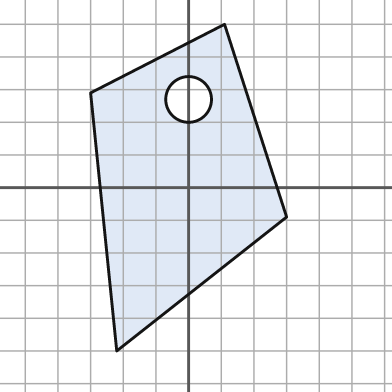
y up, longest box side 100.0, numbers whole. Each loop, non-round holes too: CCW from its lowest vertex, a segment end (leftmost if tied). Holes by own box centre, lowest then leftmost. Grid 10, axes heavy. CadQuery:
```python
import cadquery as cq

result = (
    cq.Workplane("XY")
    .moveTo(-22.0, -50.0)
    .lineTo(30.0, -9.0)
    .lineTo(11.0, 50.0)
    .lineTo(-30.0, 29.0)
    .close()
    .moveTo(0.0, 27.0)
    .circle(7.0)
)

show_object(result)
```